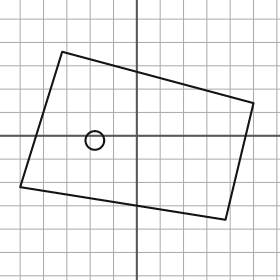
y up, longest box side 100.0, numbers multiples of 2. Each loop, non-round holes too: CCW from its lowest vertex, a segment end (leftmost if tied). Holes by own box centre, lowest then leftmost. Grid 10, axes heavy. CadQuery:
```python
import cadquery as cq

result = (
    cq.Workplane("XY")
    .moveTo(38.0, -36.0)
    .lineTo(50.0, 14.0)
    .lineTo(-32.0, 36.0)
    .lineTo(-50.0, -22.0)
    .close()
    .moveTo(-18.0, -2.0)
    .circle(4.0)
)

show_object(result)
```